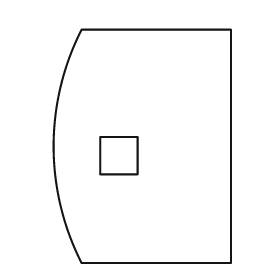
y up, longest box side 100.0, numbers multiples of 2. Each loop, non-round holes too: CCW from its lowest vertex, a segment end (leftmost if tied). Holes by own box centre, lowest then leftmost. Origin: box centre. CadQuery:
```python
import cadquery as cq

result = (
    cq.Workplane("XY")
    .moveTo(-26.0, -50.0)
    .lineTo(38.0, -50.0)
    .lineTo(38.0, 50.0)
    .lineTo(-26.0, 50.0)
    .threePointArc((-38.0, 0.0), (-26.0, -50.0))
    .close()
    .moveTo(-18.0, -12.0)
    .lineTo(-2.0, -12.0)
    .lineTo(-2.0, 4.0)
    .lineTo(-18.0, 4.0)
    .close()
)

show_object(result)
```